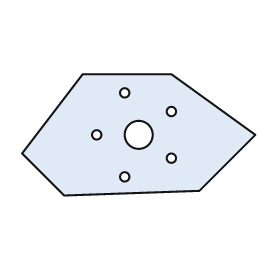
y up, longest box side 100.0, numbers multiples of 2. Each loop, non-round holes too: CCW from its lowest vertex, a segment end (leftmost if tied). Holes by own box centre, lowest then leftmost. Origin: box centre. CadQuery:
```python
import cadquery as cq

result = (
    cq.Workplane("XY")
    .moveTo(-32.0, -26.0)
    .lineTo(26.0, -24.0)
    .lineTo(50.0, 0.0)
    .lineTo(14.0, 26.0)
    .lineTo(-24.0, 26.0)
    .lineTo(-50.0, -8.0)
    .close()
    .moveTo(-6.0, -18.0)
    .circle(2.0)
    .moveTo(14.0, -10.0)
    .circle(2.0)
    .moveTo(-18.0, 0.0)
    .circle(2.0)
    .moveTo(0.0, 0.0)
    .circle(6.0)
    .moveTo(14.0, 10.0)
    .circle(2.0)
    .moveTo(-6.0, 18.0)
    .circle(2.0)
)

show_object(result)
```